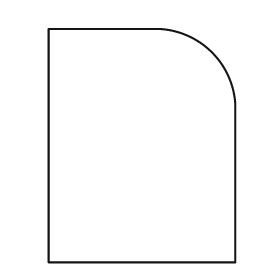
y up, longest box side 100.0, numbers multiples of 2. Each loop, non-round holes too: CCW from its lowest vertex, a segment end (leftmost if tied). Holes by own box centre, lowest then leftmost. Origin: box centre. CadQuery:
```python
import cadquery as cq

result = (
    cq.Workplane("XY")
    .moveTo(-40.0, -50.0)
    .lineTo(40.0, -50.0)
    .lineTo(40.0, 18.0)
    .threePointArc((30.0, 40.0), (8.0, 50.0))
    .lineTo(-40.0, 50.0)
    .close()
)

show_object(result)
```